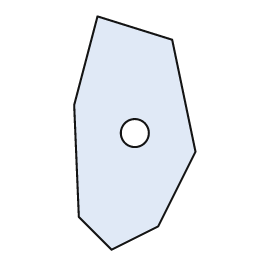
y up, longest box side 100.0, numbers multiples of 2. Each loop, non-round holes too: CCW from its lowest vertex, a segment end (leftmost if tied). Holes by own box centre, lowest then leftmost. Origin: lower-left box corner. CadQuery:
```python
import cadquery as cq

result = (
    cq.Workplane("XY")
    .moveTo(16.0, 0.0)
    .lineTo(36.0, 10.0)
    .lineTo(52.0, 42.0)
    .lineTo(42.0, 90.0)
    .lineTo(10.0, 100.0)
    .lineTo(0.0, 62.0)
    .lineTo(2.0, 14.0)
    .close()
    .moveTo(26.0, 50.0)
    .circle(6.0)
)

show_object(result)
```